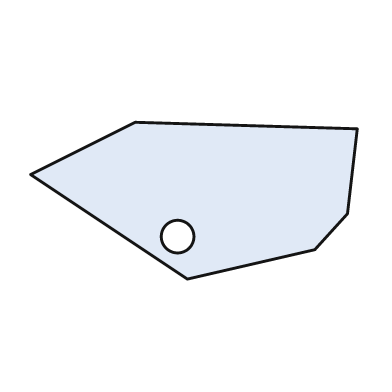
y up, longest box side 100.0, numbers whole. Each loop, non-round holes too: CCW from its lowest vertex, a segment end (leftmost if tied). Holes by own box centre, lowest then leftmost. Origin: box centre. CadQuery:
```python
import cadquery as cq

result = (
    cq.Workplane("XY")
    .moveTo(-2.0, -24.0)
    .lineTo(37.0, -15.0)
    .lineTo(47.0, -4.0)
    .lineTo(50.0, 22.0)
    .lineTo(-18.0, 24.0)
    .lineTo(-50.0, 8.0)
    .close()
    .moveTo(-5.0, -11.0)
    .circle(5.0)
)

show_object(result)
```